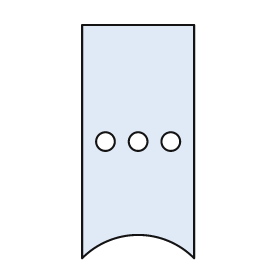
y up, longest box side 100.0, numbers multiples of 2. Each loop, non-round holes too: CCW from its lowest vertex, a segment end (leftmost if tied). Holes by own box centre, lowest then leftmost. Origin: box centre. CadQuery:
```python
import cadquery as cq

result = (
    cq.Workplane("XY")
    .moveTo(-24.0, -50.0)
    .threePointArc((0.0, -40.0), (24.0, -50.0))
    .lineTo(24.0, 50.0)
    .lineTo(-24.0, 50.0)
    .close()
    .moveTo(-14.0, 0.0)
    .circle(4.0)
    .moveTo(0.0, 0.0)
    .circle(4.0)
    .moveTo(14.0, 0.0)
    .circle(4.0)
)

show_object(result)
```